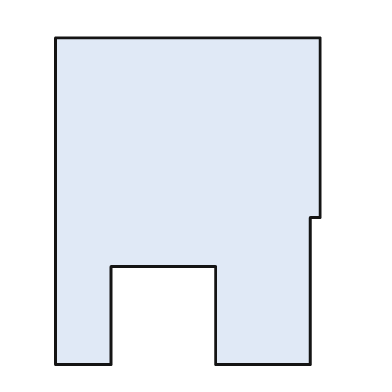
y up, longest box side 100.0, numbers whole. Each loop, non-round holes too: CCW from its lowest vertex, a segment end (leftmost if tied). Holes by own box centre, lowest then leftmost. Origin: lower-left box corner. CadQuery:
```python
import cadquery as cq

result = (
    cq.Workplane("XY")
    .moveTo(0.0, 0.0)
    .lineTo(17.0, 0.0)
    .lineTo(17.0, 30.0)
    .lineTo(49.0, 30.0)
    .lineTo(49.0, 0.0)
    .lineTo(78.0, 0.0)
    .lineTo(78.0, 45.0)
    .lineTo(81.0, 45.0)
    .lineTo(81.0, 100.0)
    .lineTo(0.0, 100.0)
    .close()
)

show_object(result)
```